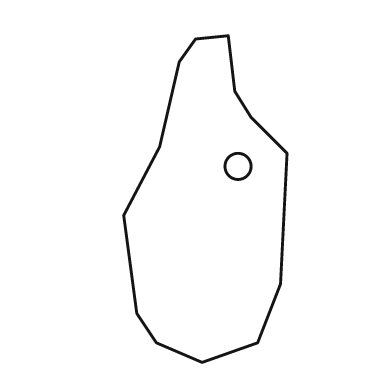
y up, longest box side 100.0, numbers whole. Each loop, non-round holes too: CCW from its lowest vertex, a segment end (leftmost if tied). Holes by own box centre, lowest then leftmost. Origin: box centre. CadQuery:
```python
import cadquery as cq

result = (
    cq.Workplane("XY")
    .moveTo(-1.0, -50.0)
    .lineTo(16.0, -44.0)
    .lineTo(23.0, -26.0)
    .lineTo(25.0, 14.0)
    .lineTo(14.0, 25.0)
    .lineTo(9.0, 33.0)
    .lineTo(7.0, 50.0)
    .lineTo(-3.0, 49.0)
    .lineTo(-8.0, 42.0)
    .lineTo(-14.0, 16.0)
    .lineTo(-25.0, -5.0)
    .lineTo(-21.0, -35.0)
    .lineTo(-15.0, -44.0)
    .close()
    .moveTo(10.0, 10.0)
    .circle(4.0)
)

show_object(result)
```